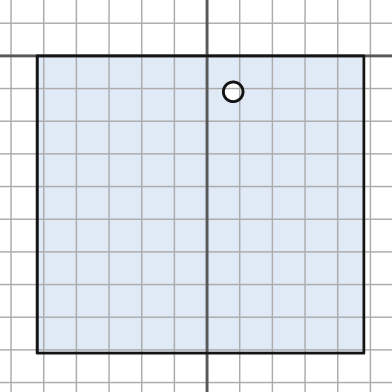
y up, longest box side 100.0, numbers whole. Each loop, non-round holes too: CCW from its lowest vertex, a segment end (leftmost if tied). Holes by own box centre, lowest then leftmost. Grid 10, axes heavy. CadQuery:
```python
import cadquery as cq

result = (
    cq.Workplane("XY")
    .moveTo(-52.0, -91.0)
    .lineTo(48.0, -91.0)
    .lineTo(48.0, 0.0)
    .lineTo(-52.0, 0.0)
    .close()
    .moveTo(8.0, -11.0)
    .circle(3.0)
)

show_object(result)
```